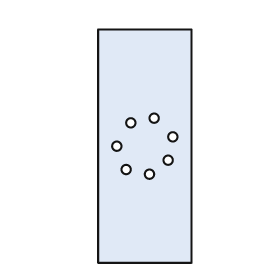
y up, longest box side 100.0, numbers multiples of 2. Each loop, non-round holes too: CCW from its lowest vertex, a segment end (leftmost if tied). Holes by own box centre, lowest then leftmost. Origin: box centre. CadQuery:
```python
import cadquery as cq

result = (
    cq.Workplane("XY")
    .moveTo(-20.0, -50.0)
    .lineTo(20.0, -50.0)
    .lineTo(20.0, 50.0)
    .lineTo(-20.0, 50.0)
    .close()
    .moveTo(2.0, -12.0)
    .circle(2.0)
    .moveTo(-8.0, -10.0)
    .circle(2.0)
    .moveTo(10.0, -6.0)
    .circle(2.0)
    .moveTo(-12.0, 0.0)
    .circle(2.0)
    .moveTo(12.0, 4.0)
    .circle(2.0)
    .moveTo(-6.0, 10.0)
    .circle(2.0)
    .moveTo(4.0, 12.0)
    .circle(2.0)
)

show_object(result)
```